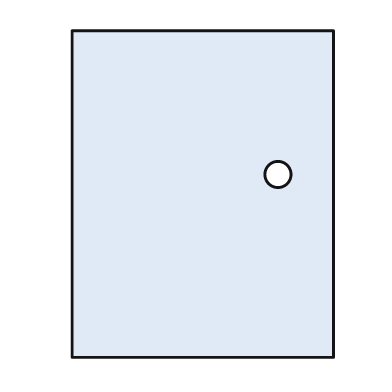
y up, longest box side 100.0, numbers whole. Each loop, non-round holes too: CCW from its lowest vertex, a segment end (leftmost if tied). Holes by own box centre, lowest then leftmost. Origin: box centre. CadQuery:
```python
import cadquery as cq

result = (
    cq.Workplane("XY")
    .moveTo(-40.0, -50.0)
    .lineTo(40.0, -50.0)
    .lineTo(40.0, 50.0)
    .lineTo(-40.0, 50.0)
    .close()
    .moveTo(23.0, 6.0)
    .circle(4.0)
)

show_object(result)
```